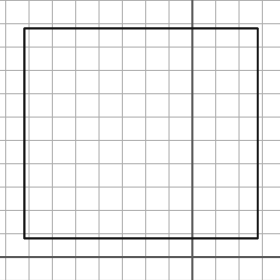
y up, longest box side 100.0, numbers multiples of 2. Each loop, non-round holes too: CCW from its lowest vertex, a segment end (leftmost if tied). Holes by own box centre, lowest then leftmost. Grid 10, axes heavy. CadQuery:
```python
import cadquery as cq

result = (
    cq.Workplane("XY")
    .moveTo(-72.0, 8.0)
    .lineTo(28.0, 8.0)
    .lineTo(28.0, 98.0)
    .lineTo(-72.0, 98.0)
    .close()
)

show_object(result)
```